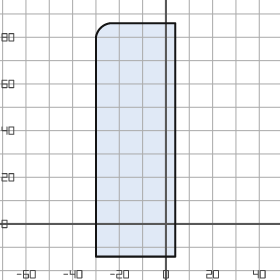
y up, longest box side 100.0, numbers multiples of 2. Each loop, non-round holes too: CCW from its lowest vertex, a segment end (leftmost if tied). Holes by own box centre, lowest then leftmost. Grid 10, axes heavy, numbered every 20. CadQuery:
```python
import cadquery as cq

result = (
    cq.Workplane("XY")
    .moveTo(-30.0, -14.0)
    .lineTo(4.0, -14.0)
    .lineTo(4.0, 86.0)
    .lineTo(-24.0, 86.0)
    .threePointArc((-28.0, 84.0), (-30.0, 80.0))
    .close()
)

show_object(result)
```